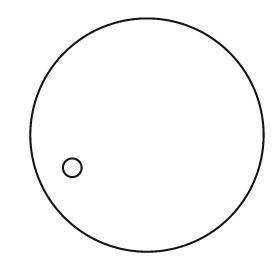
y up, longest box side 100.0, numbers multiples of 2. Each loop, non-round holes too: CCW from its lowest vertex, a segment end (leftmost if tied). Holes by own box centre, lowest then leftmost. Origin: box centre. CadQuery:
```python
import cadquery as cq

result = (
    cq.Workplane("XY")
    .moveTo(0.0, 0.0)
    .circle(50.0)
    .moveTo(-32.0, -14.0)
    .circle(4.0)
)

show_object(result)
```